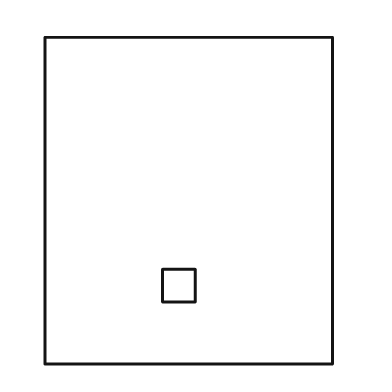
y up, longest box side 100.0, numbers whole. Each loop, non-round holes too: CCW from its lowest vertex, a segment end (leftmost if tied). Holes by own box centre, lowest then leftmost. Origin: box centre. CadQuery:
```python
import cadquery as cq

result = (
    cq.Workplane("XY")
    .moveTo(-44.0, -50.0)
    .lineTo(44.0, -50.0)
    .lineTo(44.0, 50.0)
    .lineTo(-44.0, 50.0)
    .close()
    .moveTo(-8.0, -31.0)
    .lineTo(2.0, -31.0)
    .lineTo(2.0, -21.0)
    .lineTo(-8.0, -21.0)
    .close()
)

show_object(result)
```